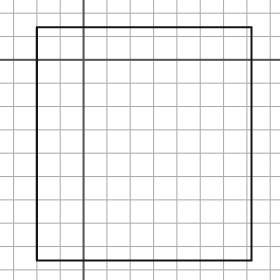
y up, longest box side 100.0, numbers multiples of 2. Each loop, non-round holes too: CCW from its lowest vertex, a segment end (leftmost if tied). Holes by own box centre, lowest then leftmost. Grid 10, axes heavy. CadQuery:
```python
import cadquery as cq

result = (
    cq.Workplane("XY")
    .moveTo(-20.0, -86.0)
    .lineTo(72.0, -86.0)
    .lineTo(72.0, 14.0)
    .lineTo(-20.0, 14.0)
    .close()
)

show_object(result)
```